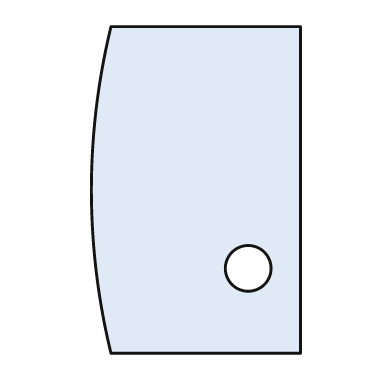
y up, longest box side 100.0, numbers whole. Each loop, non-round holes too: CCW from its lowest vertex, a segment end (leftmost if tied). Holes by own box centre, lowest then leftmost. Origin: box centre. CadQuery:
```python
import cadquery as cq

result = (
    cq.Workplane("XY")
    .moveTo(-26.0, -50.0)
    .lineTo(32.0, -50.0)
    .lineTo(32.0, 50.0)
    .lineTo(-26.0, 50.0)
    .threePointArc((-32.0, 0.0), (-26.0, -50.0))
    .close()
    .moveTo(16.0, -24.0)
    .circle(7.0)
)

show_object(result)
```